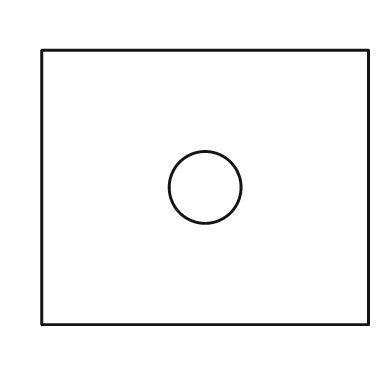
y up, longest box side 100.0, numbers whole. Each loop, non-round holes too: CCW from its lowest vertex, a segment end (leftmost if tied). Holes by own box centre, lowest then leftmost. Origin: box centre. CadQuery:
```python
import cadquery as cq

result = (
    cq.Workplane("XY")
    .moveTo(-50.0, -42.0)
    .lineTo(50.0, -42.0)
    .lineTo(50.0, 42.0)
    .lineTo(-50.0, 42.0)
    .close()
    .moveTo(0.0, 0.0)
    .circle(11.0)
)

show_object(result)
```